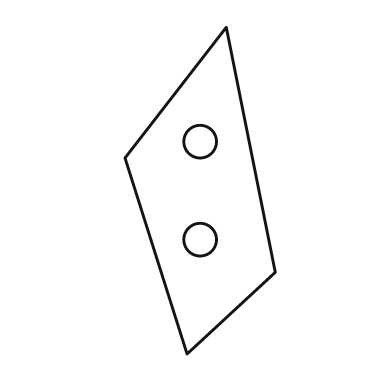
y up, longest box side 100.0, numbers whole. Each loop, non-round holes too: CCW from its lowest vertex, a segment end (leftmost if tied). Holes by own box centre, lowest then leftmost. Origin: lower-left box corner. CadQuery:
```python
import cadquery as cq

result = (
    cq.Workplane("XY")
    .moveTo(19.0, 0.0)
    .lineTo(46.0, 25.0)
    .lineTo(31.0, 100.0)
    .lineTo(0.0, 60.0)
    .close()
    .moveTo(23.0, 35.0)
    .circle(5.0)
    .moveTo(23.0, 65.0)
    .circle(5.0)
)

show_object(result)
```